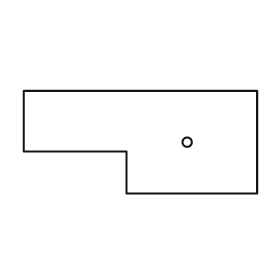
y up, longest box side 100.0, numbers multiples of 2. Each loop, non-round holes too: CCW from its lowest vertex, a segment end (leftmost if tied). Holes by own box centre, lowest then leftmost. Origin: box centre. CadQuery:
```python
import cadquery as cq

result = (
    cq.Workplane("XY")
    .moveTo(-6.0, -22.0)
    .lineTo(50.0, -22.0)
    .lineTo(50.0, 22.0)
    .lineTo(-50.0, 22.0)
    .lineTo(-50.0, -4.0)
    .lineTo(-6.0, -4.0)
    .close()
    .moveTo(20.0, 0.0)
    .circle(2.0)
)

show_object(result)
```